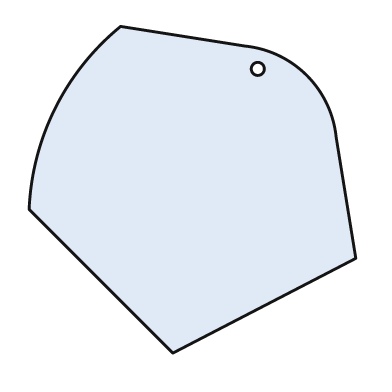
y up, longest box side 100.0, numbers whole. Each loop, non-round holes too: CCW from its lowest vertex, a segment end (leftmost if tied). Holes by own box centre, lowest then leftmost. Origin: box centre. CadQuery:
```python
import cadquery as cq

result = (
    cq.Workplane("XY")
    .moveTo(-6.0, -50.0)
    .lineTo(50.0, -21.0)
    .lineTo(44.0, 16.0)
    .threePointArc((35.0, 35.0), (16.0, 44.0))
    .lineTo(-22.0, 50.0)
    .threePointArc((-42.0, 25.0), (-50.0, -6.0))
    .close()
    .moveTo(20.0, 37.0)
    .circle(2.0)
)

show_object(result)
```